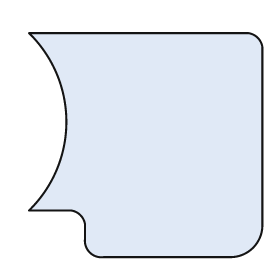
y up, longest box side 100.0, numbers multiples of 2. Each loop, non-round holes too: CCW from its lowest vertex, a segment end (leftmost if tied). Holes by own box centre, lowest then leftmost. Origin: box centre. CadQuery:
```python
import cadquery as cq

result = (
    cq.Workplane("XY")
    .moveTo(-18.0, -48.0)
    .lineTo(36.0, -48.0)
    .threePointArc((46.0, -44.0), (50.0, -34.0))
    .lineTo(50.0, 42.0)
    .threePointArc((48.0, 46.0), (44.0, 48.0))
    .lineTo(-50.0, 48.0)
    .threePointArc((-34.0, 10.0), (-50.0, -28.0))
    .lineTo(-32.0, -28.0)
    .threePointArc((-28.0, -30.0), (-26.0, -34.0))
    .lineTo(-26.0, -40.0)
    .threePointArc((-24.0, -46.0), (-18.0, -48.0))
    .close()
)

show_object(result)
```